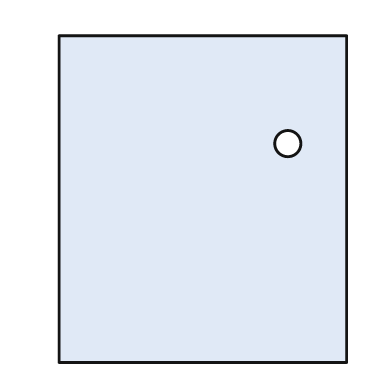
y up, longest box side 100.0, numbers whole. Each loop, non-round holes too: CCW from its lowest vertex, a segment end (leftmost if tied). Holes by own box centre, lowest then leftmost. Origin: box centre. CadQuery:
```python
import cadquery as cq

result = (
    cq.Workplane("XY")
    .moveTo(-44.0, -50.0)
    .lineTo(44.0, -50.0)
    .lineTo(44.0, 50.0)
    .lineTo(-44.0, 50.0)
    .close()
    .moveTo(26.0, 17.0)
    .circle(4.0)
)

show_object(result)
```